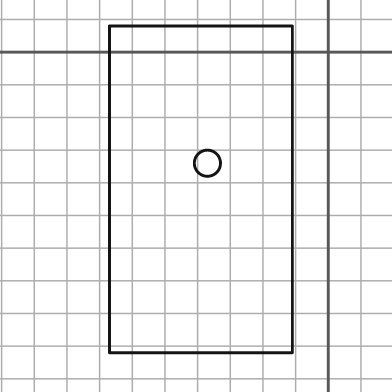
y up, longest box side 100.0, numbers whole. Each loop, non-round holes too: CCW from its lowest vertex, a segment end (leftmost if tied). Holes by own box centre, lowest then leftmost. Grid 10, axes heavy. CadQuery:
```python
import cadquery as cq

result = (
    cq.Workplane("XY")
    .moveTo(-67.0, -92.0)
    .lineTo(-11.0, -92.0)
    .lineTo(-11.0, 8.0)
    .lineTo(-67.0, 8.0)
    .close()
    .moveTo(-37.0, -34.0)
    .circle(4.0)
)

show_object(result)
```